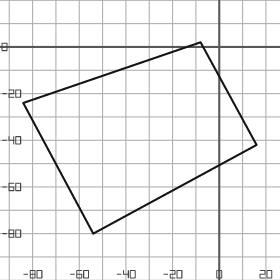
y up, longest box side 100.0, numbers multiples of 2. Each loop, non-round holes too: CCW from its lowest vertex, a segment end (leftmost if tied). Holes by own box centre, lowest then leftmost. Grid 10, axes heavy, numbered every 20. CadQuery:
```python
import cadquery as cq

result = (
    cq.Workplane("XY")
    .moveTo(-54.0, -80.0)
    .lineTo(16.0, -42.0)
    .lineTo(-8.0, 2.0)
    .lineTo(-84.0, -24.0)
    .close()
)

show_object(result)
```